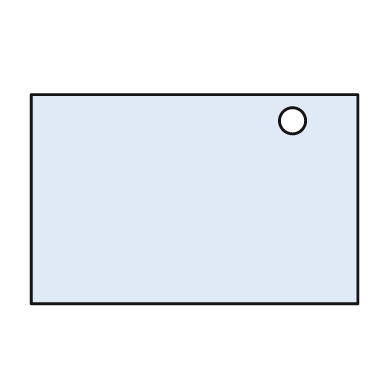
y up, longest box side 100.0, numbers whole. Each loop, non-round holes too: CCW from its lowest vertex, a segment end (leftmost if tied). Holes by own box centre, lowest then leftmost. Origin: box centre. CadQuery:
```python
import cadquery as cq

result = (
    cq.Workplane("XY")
    .moveTo(-50.0, -32.0)
    .lineTo(50.0, -32.0)
    .lineTo(50.0, 32.0)
    .lineTo(-50.0, 32.0)
    .close()
    .moveTo(30.0, 24.0)
    .circle(4.0)
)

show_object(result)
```